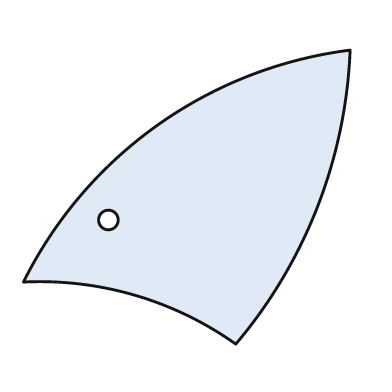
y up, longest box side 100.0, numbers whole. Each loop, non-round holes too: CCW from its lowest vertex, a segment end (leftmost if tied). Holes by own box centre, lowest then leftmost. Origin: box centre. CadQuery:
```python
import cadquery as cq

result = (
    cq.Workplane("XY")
    .moveTo(15.0, -45.0)
    .threePointArc((40.0, -3.0), (50.0, 45.0))
    .threePointArc((-9.0, 22.0), (-50.0, -26.0))
    .threePointArc((-16.0, -30.0), (15.0, -45.0))
    .close()
    .moveTo(-24.0, -7.0)
    .circle(3.0)
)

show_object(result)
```